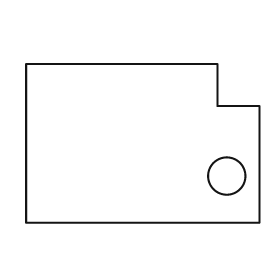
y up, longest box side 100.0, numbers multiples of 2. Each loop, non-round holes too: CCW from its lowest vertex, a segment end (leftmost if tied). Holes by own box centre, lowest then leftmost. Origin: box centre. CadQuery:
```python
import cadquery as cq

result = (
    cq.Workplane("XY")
    .moveTo(-50.0, -34.0)
    .lineTo(50.0, -34.0)
    .lineTo(50.0, 16.0)
    .lineTo(32.0, 16.0)
    .lineTo(32.0, 34.0)
    .lineTo(-50.0, 34.0)
    .close()
    .moveTo(36.0, -14.0)
    .circle(8.0)
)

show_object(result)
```